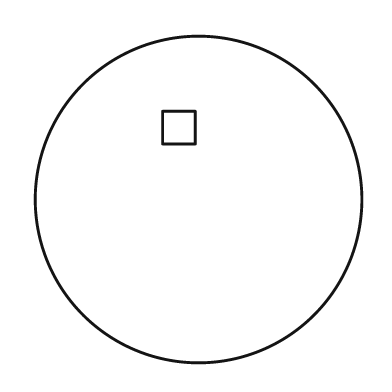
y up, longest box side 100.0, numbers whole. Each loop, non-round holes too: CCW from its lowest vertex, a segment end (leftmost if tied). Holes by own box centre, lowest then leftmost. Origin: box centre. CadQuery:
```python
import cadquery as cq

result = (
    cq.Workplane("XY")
    .moveTo(0.0, 0.0)
    .circle(50.0)
    .moveTo(-11.0, 17.0)
    .lineTo(-1.0, 17.0)
    .lineTo(-1.0, 27.0)
    .lineTo(-11.0, 27.0)
    .close()
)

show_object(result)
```